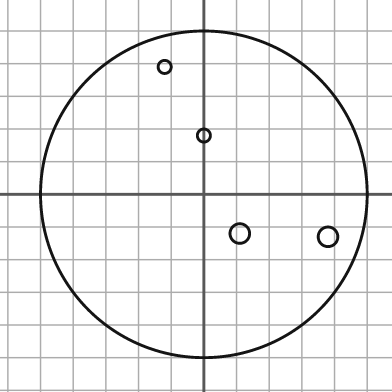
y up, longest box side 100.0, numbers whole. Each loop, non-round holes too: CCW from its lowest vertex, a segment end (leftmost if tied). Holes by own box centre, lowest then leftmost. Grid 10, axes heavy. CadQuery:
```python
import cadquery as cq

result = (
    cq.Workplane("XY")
    .moveTo(0.0, 0.0)
    .circle(50.0)
    .moveTo(38.0, -13.0)
    .circle(3.0)
    .moveTo(11.0, -12.0)
    .circle(3.0)
    .moveTo(0.0, 18.0)
    .circle(2.0)
    .moveTo(-12.0, 39.0)
    .circle(2.0)
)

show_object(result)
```